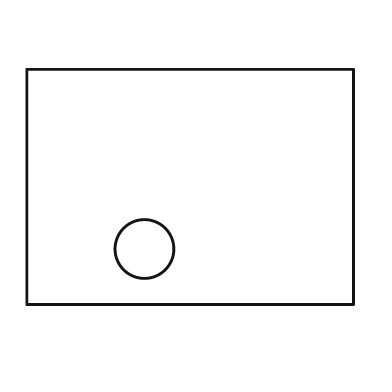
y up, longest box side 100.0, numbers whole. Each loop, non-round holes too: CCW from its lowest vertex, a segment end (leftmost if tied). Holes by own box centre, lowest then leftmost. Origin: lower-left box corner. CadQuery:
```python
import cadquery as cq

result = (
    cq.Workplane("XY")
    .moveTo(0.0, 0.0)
    .lineTo(100.0, 0.0)
    .lineTo(100.0, 72.0)
    .lineTo(0.0, 72.0)
    .close()
    .moveTo(36.0, 17.0)
    .circle(9.0)
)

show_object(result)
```